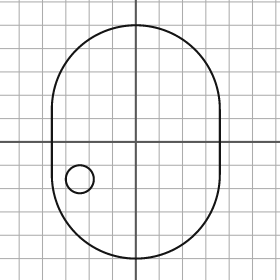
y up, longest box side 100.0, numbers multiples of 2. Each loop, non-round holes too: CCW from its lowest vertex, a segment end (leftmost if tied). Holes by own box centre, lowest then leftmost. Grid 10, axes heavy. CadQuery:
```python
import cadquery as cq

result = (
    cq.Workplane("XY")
    .moveTo(-36.0, -14.0)
    .threePointArc((0.0, -50.0), (36.0, -14.0))
    .lineTo(36.0, 14.0)
    .threePointArc((0.0, 50.0), (-36.0, 14.0))
    .close()
    .moveTo(-24.0, -16.0)
    .circle(6.0)
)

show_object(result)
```